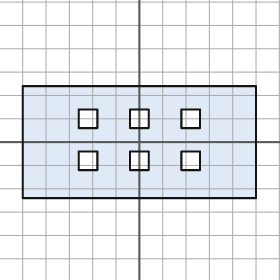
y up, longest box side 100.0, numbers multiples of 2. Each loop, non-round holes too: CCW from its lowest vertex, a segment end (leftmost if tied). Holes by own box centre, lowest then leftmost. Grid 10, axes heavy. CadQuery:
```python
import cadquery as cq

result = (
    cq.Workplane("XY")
    .moveTo(-50.0, -24.0)
    .lineTo(50.0, -24.0)
    .lineTo(50.0, 24.0)
    .lineTo(-50.0, 24.0)
    .close()
    .moveTo(-26.0, -12.0)
    .lineTo(-18.0, -12.0)
    .lineTo(-18.0, -4.0)
    .lineTo(-26.0, -4.0)
    .close()
    .moveTo(-4.0, -12.0)
    .lineTo(4.0, -12.0)
    .lineTo(4.0, -4.0)
    .lineTo(-4.0, -4.0)
    .close()
    .moveTo(18.0, -12.0)
    .lineTo(26.0, -12.0)
    .lineTo(26.0, -4.0)
    .lineTo(18.0, -4.0)
    .close()
    .moveTo(-26.0, 6.0)
    .lineTo(-18.0, 6.0)
    .lineTo(-18.0, 14.0)
    .lineTo(-26.0, 14.0)
    .close()
    .moveTo(-4.0, 6.0)
    .lineTo(4.0, 6.0)
    .lineTo(4.0, 14.0)
    .lineTo(-4.0, 14.0)
    .close()
    .moveTo(18.0, 6.0)
    .lineTo(26.0, 6.0)
    .lineTo(26.0, 14.0)
    .lineTo(18.0, 14.0)
    .close()
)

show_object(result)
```